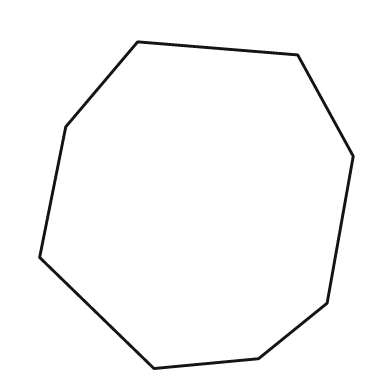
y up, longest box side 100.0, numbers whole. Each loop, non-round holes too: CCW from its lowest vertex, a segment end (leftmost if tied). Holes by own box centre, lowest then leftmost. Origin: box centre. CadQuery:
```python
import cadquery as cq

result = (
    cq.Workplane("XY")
    .moveTo(-13.0, -50.0)
    .lineTo(19.0, -47.0)
    .lineTo(40.0, -30.0)
    .lineTo(48.0, 15.0)
    .lineTo(31.0, 46.0)
    .lineTo(-18.0, 50.0)
    .lineTo(-40.0, 24.0)
    .lineTo(-48.0, -16.0)
    .close()
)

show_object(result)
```